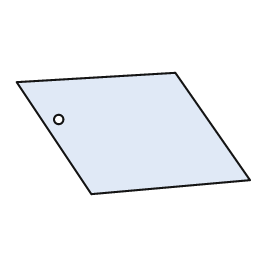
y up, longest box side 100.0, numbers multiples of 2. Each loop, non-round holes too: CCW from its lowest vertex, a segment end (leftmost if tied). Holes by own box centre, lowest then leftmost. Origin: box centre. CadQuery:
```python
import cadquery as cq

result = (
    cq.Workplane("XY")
    .moveTo(-18.0, -26.0)
    .lineTo(50.0, -20.0)
    .lineTo(18.0, 26.0)
    .lineTo(-50.0, 22.0)
    .close()
    .moveTo(-32.0, 6.0)
    .circle(2.0)
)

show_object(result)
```